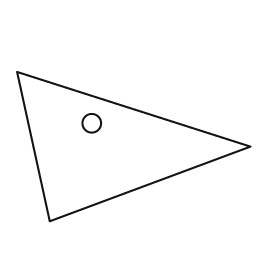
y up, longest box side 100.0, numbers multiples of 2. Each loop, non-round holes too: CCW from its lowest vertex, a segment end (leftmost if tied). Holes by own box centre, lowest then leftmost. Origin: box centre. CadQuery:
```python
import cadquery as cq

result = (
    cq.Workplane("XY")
    .moveTo(-36.0, -32.0)
    .lineTo(50.0, 0.0)
    .lineTo(-50.0, 32.0)
    .close()
    .moveTo(-18.0, 10.0)
    .circle(4.0)
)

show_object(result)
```